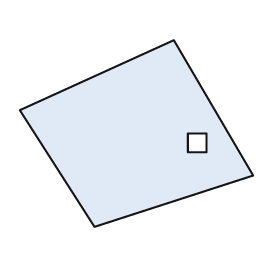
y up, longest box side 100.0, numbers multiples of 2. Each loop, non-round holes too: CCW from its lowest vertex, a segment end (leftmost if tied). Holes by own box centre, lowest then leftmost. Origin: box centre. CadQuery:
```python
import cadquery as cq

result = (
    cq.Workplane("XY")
    .moveTo(-18.0, -40.0)
    .lineTo(50.0, -18.0)
    .lineTo(16.0, 40.0)
    .lineTo(-50.0, 10.0)
    .close()
    .moveTo(22.0, -8.0)
    .lineTo(30.0, -8.0)
    .lineTo(30.0, 0.0)
    .lineTo(22.0, 0.0)
    .close()
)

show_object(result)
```